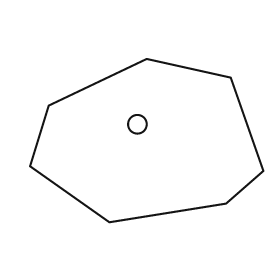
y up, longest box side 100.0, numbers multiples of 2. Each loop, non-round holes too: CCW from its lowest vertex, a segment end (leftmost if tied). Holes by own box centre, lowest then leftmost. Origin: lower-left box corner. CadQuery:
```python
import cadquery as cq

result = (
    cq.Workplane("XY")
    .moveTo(34.0, 0.0)
    .lineTo(84.0, 8.0)
    .lineTo(100.0, 22.0)
    .lineTo(86.0, 62.0)
    .lineTo(50.0, 70.0)
    .lineTo(8.0, 50.0)
    .lineTo(0.0, 24.0)
    .close()
    .moveTo(46.0, 42.0)
    .circle(4.0)
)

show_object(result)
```